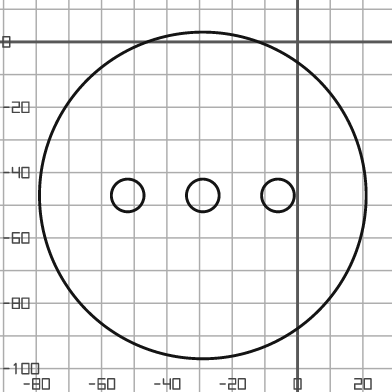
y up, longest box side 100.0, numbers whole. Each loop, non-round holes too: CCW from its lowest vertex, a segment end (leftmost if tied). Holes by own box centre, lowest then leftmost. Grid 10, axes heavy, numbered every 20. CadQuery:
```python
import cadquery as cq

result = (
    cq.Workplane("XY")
    .moveTo(-29.0, -47.0)
    .circle(50.0)
    .moveTo(-52.0, -47.0)
    .circle(5.0)
    .moveTo(-29.0, -47.0)
    .circle(5.0)
    .moveTo(-6.0, -47.0)
    .circle(5.0)
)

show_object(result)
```